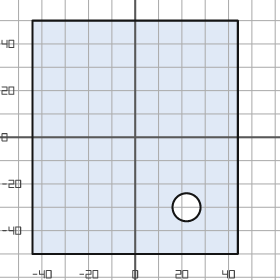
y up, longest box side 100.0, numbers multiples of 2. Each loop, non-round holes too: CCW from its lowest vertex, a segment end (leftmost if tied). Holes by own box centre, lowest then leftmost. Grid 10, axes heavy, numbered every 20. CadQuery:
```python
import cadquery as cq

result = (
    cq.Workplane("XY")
    .moveTo(-44.0, -50.0)
    .lineTo(44.0, -50.0)
    .lineTo(44.0, 50.0)
    .lineTo(-44.0, 50.0)
    .close()
    .moveTo(22.0, -30.0)
    .circle(6.0)
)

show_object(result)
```